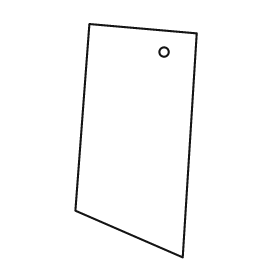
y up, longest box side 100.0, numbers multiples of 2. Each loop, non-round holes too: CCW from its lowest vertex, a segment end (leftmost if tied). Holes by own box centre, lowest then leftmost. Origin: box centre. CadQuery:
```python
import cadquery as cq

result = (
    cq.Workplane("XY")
    .moveTo(20.0, -50.0)
    .lineTo(26.0, 46.0)
    .lineTo(-20.0, 50.0)
    .lineTo(-26.0, -30.0)
    .close()
    .moveTo(12.0, 38.0)
    .circle(2.0)
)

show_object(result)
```